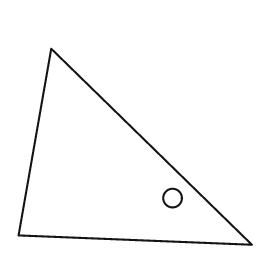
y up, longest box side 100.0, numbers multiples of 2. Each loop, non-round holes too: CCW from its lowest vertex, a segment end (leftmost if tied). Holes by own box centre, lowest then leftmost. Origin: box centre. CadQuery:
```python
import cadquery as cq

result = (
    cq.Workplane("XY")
    .moveTo(50.0, -42.0)
    .lineTo(-36.0, 42.0)
    .lineTo(-50.0, -38.0)
    .close()
    .moveTo(16.0, -22.0)
    .circle(4.0)
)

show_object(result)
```